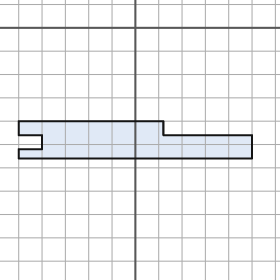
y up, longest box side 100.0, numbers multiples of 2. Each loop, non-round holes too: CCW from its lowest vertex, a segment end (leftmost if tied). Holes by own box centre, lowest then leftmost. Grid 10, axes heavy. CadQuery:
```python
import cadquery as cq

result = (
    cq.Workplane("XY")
    .moveTo(-50.0, -56.0)
    .lineTo(50.0, -56.0)
    .lineTo(50.0, -46.0)
    .lineTo(12.0, -46.0)
    .lineTo(12.0, -40.0)
    .lineTo(-50.0, -40.0)
    .lineTo(-50.0, -46.0)
    .lineTo(-40.0, -46.0)
    .lineTo(-40.0, -52.0)
    .lineTo(-50.0, -52.0)
    .close()
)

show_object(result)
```